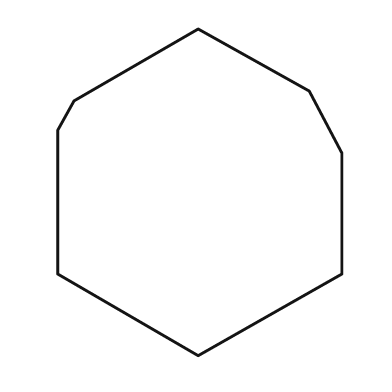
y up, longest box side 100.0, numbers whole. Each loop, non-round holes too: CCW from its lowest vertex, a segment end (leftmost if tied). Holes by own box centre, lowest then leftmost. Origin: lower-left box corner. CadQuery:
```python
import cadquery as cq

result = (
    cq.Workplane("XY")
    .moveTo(43.0, 0.0)
    .lineTo(87.0, 25.0)
    .lineTo(87.0, 62.0)
    .lineTo(77.0, 81.0)
    .lineTo(43.0, 100.0)
    .lineTo(5.0, 78.0)
    .lineTo(0.0, 69.0)
    .lineTo(0.0, 25.0)
    .close()
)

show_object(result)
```